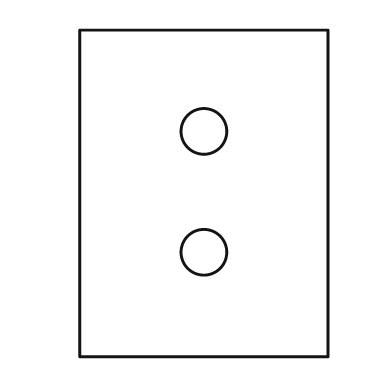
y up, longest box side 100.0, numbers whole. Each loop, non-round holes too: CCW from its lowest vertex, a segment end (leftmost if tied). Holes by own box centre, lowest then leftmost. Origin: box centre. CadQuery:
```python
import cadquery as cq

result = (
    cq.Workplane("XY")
    .moveTo(-38.0, -50.0)
    .lineTo(38.0, -50.0)
    .lineTo(38.0, 50.0)
    .lineTo(-38.0, 50.0)
    .close()
    .moveTo(0.0, -18.0)
    .circle(7.0)
    .moveTo(0.0, 19.0)
    .circle(7.0)
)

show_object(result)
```